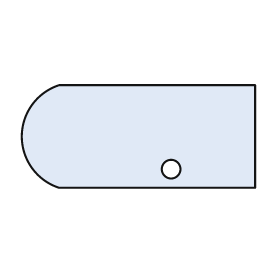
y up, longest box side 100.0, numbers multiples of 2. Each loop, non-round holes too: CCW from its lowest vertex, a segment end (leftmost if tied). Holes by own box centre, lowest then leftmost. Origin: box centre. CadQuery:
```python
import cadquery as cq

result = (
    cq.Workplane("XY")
    .moveTo(-34.0, -22.0)
    .lineTo(50.0, -22.0)
    .lineTo(50.0, 22.0)
    .lineTo(-34.0, 22.0)
    .threePointArc((-50.0, 0.0), (-34.0, -22.0))
    .close()
    .moveTo(14.0, -14.0)
    .circle(4.0)
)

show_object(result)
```